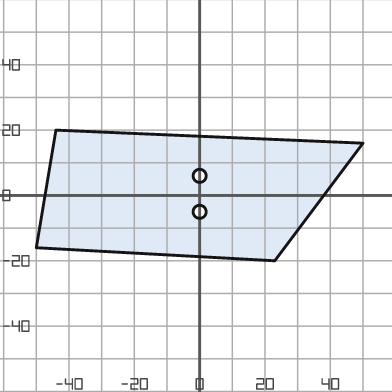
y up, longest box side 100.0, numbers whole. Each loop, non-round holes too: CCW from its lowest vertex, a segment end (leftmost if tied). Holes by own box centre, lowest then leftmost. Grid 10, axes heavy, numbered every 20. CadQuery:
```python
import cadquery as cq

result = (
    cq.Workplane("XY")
    .moveTo(23.0, -20.0)
    .lineTo(50.0, 16.0)
    .lineTo(-44.0, 20.0)
    .lineTo(-50.0, -16.0)
    .close()
    .moveTo(0.0, -5.0)
    .circle(2.0)
    .moveTo(0.0, 6.0)
    .circle(2.0)
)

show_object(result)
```